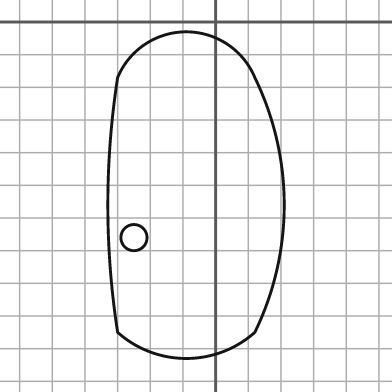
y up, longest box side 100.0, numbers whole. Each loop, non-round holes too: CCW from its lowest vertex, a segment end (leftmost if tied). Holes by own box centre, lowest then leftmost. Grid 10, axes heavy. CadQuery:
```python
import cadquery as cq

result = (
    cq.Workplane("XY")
    .moveTo(-30.0, -95.0)
    .threePointArc((-9.0, -103.0), (12.0, -95.0))
    .threePointArc((21.0, -56.0), (12.0, -17.0))
    .threePointArc((-9.0, -3.0), (-30.0, -17.0))
    .threePointArc((-33.0, -56.0), (-30.0, -95.0))
    .close()
    .moveTo(-25.0, -66.0)
    .circle(4.0)
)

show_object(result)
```